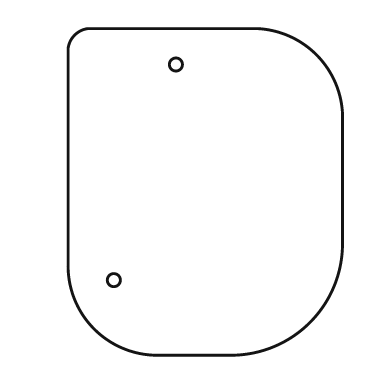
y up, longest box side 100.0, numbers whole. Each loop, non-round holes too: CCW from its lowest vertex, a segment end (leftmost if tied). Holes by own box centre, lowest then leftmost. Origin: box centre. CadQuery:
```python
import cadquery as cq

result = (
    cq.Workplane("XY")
    .moveTo(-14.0, -50.0)
    .lineTo(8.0, -50.0)
    .threePointArc((32.0, -40.0), (42.0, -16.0))
    .lineTo(42.0, 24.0)
    .threePointArc((34.0, 42.0), (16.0, 50.0))
    .lineTo(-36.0, 50.0)
    .threePointArc((-40.0, 48.0), (-42.0, 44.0))
    .lineTo(-42.0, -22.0)
    .threePointArc((-34.0, -42.0), (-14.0, -50.0))
    .close()
    .moveTo(-28.0, -27.0)
    .circle(2.0)
    .moveTo(-9.0, 39.0)
    .circle(2.0)
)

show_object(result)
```